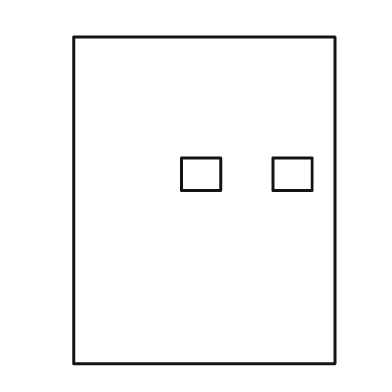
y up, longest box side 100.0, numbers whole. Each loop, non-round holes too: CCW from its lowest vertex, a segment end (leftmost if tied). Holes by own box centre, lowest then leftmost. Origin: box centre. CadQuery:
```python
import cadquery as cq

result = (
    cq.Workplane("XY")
    .moveTo(-40.0, -50.0)
    .lineTo(40.0, -50.0)
    .lineTo(40.0, 50.0)
    .lineTo(-40.0, 50.0)
    .close()
    .moveTo(-7.0, 3.0)
    .lineTo(5.0, 3.0)
    .lineTo(5.0, 13.0)
    .lineTo(-7.0, 13.0)
    .close()
    .moveTo(21.0, 3.0)
    .lineTo(33.0, 3.0)
    .lineTo(33.0, 13.0)
    .lineTo(21.0, 13.0)
    .close()
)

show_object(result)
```